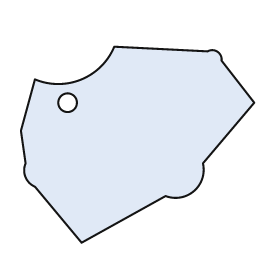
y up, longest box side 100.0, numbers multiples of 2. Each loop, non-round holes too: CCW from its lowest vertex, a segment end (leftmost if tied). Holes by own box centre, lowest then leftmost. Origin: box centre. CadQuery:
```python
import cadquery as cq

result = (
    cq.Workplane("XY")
    .moveTo(-24.0, -42.0)
    .lineTo(12.0, -22.0)
    .threePointArc((24.0, -20.0), (28.0, -8.0))
    .lineTo(50.0, 18.0)
    .lineTo(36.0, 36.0)
    .threePointArc((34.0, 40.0), (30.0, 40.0))
    .lineTo(-10.0, 42.0)
    .threePointArc((-24.0, 28.0), (-44.0, 28.0))
    .lineTo(-50.0, 6.0)
    .lineTo(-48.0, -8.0)
    .threePointArc((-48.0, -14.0), (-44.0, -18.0))
    .close()
    .moveTo(-30.0, 18.0)
    .circle(4.0)
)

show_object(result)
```